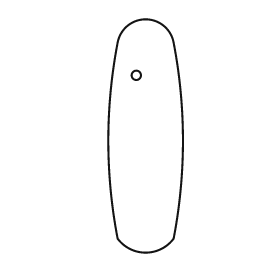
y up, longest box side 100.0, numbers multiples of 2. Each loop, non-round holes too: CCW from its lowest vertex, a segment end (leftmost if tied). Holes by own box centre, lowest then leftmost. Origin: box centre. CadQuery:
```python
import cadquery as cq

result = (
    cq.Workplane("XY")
    .moveTo(-12.0, -44.0)
    .threePointArc((0.0, -50.0), (12.0, -44.0))
    .threePointArc((16.0, -2.0), (12.0, 40.0))
    .threePointArc((0.0, 50.0), (-12.0, 40.0))
    .threePointArc((-16.0, -2.0), (-12.0, -44.0))
    .close()
    .moveTo(-4.0, 26.0)
    .circle(2.0)
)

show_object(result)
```